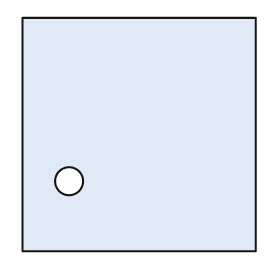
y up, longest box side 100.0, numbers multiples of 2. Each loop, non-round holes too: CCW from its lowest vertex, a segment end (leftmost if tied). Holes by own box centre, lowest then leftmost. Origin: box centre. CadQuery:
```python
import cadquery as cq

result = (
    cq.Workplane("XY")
    .moveTo(-50.0, -50.0)
    .lineTo(50.0, -50.0)
    .lineTo(50.0, 50.0)
    .lineTo(-50.0, 50.0)
    .close()
    .moveTo(-30.0, -20.0)
    .circle(6.0)
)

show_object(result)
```